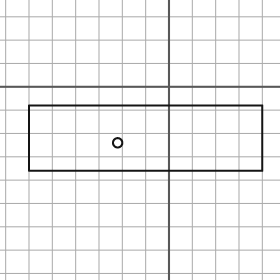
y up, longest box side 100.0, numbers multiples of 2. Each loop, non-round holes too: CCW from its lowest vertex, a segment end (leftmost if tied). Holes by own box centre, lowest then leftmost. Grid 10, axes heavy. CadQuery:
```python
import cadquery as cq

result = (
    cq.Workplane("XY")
    .moveTo(-60.0, -36.0)
    .lineTo(40.0, -36.0)
    .lineTo(40.0, -8.0)
    .lineTo(-60.0, -8.0)
    .close()
    .moveTo(-22.0, -24.0)
    .circle(2.0)
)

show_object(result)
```